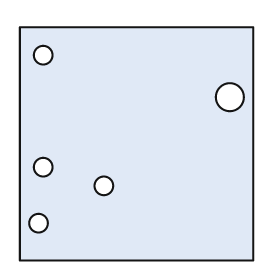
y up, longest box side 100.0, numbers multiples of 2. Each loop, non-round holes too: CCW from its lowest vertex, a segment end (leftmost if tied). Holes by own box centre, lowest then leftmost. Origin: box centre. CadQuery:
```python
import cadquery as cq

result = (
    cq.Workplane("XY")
    .moveTo(-50.0, -50.0)
    .lineTo(50.0, -50.0)
    .lineTo(50.0, 50.0)
    .lineTo(-50.0, 50.0)
    .close()
    .moveTo(-42.0, -34.0)
    .circle(4.0)
    .moveTo(-14.0, -18.0)
    .circle(4.0)
    .moveTo(-40.0, -10.0)
    .circle(4.0)
    .moveTo(40.0, 20.0)
    .circle(6.0)
    .moveTo(-40.0, 38.0)
    .circle(4.0)
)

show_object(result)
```